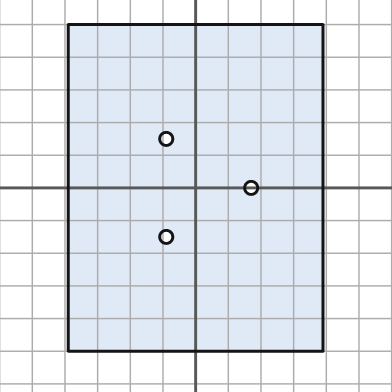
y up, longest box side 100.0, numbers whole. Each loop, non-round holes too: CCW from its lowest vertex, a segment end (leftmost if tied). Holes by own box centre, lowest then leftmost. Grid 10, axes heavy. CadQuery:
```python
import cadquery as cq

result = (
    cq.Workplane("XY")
    .moveTo(-39.0, -50.0)
    .lineTo(39.0, -50.0)
    .lineTo(39.0, 50.0)
    .lineTo(-39.0, 50.0)
    .close()
    .moveTo(-9.0, -15.0)
    .circle(2.0)
    .moveTo(17.0, 0.0)
    .circle(2.0)
    .moveTo(-9.0, 15.0)
    .circle(2.0)
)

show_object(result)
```